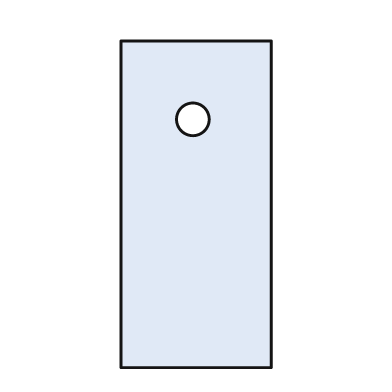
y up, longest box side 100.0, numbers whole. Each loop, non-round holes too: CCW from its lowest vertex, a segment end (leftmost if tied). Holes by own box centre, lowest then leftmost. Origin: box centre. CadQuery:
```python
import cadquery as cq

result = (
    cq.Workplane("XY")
    .moveTo(-23.0, -50.0)
    .lineTo(23.0, -50.0)
    .lineTo(23.0, 50.0)
    .lineTo(-23.0, 50.0)
    .close()
    .moveTo(-1.0, 26.0)
    .circle(5.0)
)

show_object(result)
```